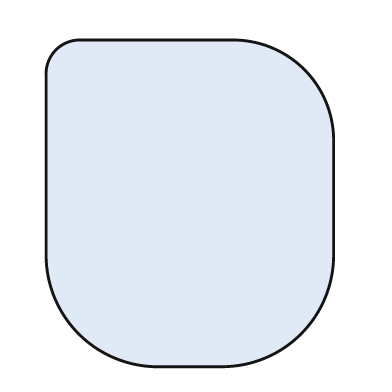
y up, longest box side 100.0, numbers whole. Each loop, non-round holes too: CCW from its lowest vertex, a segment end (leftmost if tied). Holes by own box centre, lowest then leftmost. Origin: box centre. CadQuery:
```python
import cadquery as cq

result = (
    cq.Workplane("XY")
    .moveTo(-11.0, -50.0)
    .lineTo(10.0, -50.0)
    .threePointArc((34.0, -40.0), (44.0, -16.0))
    .lineTo(44.0, 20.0)
    .threePointArc((35.0, 41.0), (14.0, 50.0))
    .lineTo(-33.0, 50.0)
    .threePointArc((-41.0, 47.0), (-44.0, 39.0))
    .lineTo(-44.0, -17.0)
    .threePointArc((-34.0, -40.0), (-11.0, -50.0))
    .close()
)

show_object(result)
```